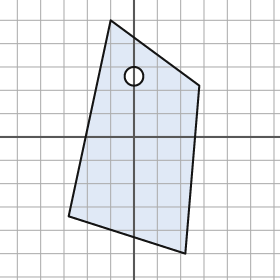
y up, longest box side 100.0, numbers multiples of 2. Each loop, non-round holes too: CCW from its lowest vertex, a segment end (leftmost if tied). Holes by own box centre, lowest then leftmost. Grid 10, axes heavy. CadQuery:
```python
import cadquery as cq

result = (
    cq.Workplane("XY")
    .moveTo(22.0, -50.0)
    .lineTo(28.0, 22.0)
    .lineTo(-10.0, 50.0)
    .lineTo(-28.0, -34.0)
    .close()
    .moveTo(0.0, 26.0)
    .circle(4.0)
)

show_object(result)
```